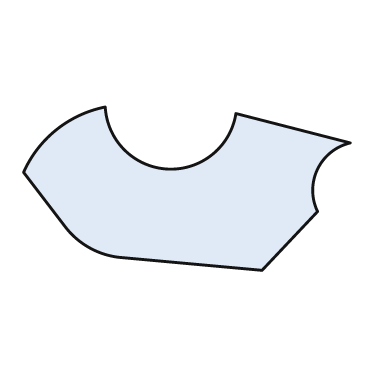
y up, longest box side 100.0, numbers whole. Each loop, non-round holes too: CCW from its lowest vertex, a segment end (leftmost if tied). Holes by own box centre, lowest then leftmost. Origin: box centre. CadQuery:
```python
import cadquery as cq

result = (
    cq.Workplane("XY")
    .moveTo(23.0, -25.0)
    .lineTo(40.0, -7.0)
    .threePointArc((40.0, 6.0), (50.0, 14.0))
    .lineTo(15.0, 23.0)
    .threePointArc((-6.0, 6.0), (-25.0, 25.0))
    .threePointArc((-40.0, 18.0), (-50.0, 5.0))
    .lineTo(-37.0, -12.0)
    .threePointArc((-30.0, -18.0), (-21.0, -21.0))
    .close()
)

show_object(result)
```